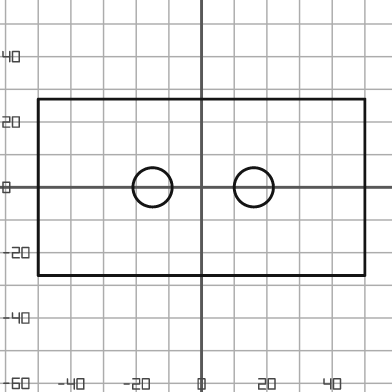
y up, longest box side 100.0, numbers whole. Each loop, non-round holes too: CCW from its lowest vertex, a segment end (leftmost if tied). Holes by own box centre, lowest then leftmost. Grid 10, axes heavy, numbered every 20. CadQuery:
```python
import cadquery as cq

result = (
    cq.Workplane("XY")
    .moveTo(-50.0, -27.0)
    .lineTo(50.0, -27.0)
    .lineTo(50.0, 27.0)
    .lineTo(-50.0, 27.0)
    .close()
    .moveTo(-15.0, 0.0)
    .circle(6.0)
    .moveTo(16.0, 0.0)
    .circle(6.0)
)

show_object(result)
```